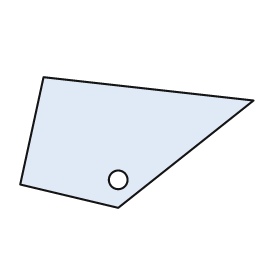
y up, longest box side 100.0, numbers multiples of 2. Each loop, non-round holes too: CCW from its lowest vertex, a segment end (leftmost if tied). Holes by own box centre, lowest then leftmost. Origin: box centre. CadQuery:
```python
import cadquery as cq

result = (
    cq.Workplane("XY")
    .moveTo(-8.0, -28.0)
    .lineTo(50.0, 18.0)
    .lineTo(-40.0, 28.0)
    .lineTo(-50.0, -18.0)
    .close()
    .moveTo(-8.0, -16.0)
    .circle(4.0)
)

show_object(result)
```